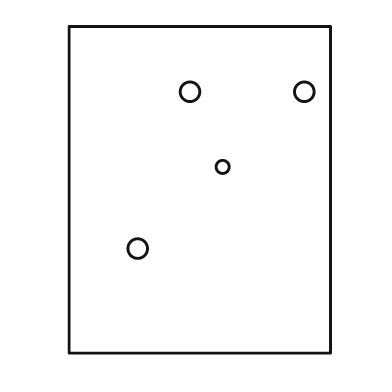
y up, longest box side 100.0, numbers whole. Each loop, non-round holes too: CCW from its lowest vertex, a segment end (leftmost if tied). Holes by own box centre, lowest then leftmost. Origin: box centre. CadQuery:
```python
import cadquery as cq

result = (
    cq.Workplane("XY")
    .moveTo(-40.0, -50.0)
    .lineTo(40.0, -50.0)
    .lineTo(40.0, 50.0)
    .lineTo(-40.0, 50.0)
    .close()
    .moveTo(-19.0, -18.0)
    .circle(3.0)
    .moveTo(7.0, 7.0)
    .circle(2.0)
    .moveTo(-3.0, 30.0)
    .circle(3.0)
    .moveTo(32.0, 30.0)
    .circle(3.0)
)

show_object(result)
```